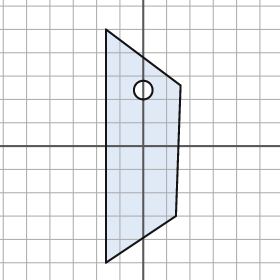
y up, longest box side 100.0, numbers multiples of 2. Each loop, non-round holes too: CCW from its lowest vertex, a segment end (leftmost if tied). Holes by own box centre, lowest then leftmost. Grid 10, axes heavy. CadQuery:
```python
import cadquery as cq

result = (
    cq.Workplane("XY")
    .moveTo(-16.0, -50.0)
    .lineTo(14.0, -30.0)
    .lineTo(16.0, 26.0)
    .lineTo(-16.0, 50.0)
    .close()
    .moveTo(0.0, 24.0)
    .circle(4.0)
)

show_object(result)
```